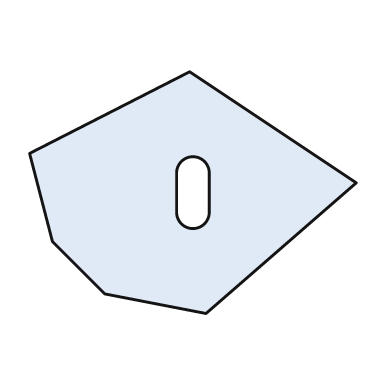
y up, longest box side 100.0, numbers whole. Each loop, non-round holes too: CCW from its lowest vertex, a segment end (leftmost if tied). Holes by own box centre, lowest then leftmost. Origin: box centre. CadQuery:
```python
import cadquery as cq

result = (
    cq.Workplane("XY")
    .moveTo(4.0, -37.0)
    .lineTo(50.0, 3.0)
    .lineTo(-1.0, 37.0)
    .lineTo(-50.0, 12.0)
    .lineTo(-43.0, -15.0)
    .lineTo(-27.0, -31.0)
    .close()
    .moveTo(-5.0, -6.0)
    .threePointArc((0.0, -11.0), (5.0, -6.0))
    .lineTo(5.0, 6.0)
    .threePointArc((0.0, 11.0), (-5.0, 6.0))
    .close()
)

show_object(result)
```